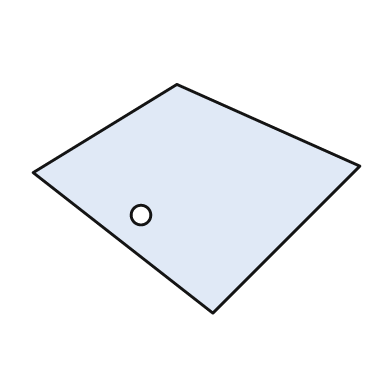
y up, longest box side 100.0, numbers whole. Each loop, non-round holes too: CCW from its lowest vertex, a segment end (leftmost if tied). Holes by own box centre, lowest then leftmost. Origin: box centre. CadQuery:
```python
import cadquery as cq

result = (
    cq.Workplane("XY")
    .moveTo(5.0, -35.0)
    .lineTo(50.0, 10.0)
    .lineTo(-6.0, 35.0)
    .lineTo(-50.0, 8.0)
    .close()
    .moveTo(-17.0, -5.0)
    .circle(3.0)
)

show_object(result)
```